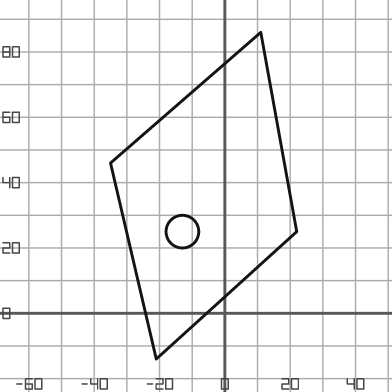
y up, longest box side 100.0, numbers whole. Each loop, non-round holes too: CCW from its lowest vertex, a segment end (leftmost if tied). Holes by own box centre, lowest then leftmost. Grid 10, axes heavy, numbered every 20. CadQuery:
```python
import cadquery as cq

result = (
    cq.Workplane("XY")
    .moveTo(-21.0, -14.0)
    .lineTo(22.0, 25.0)
    .lineTo(11.0, 86.0)
    .lineTo(-35.0, 46.0)
    .close()
    .moveTo(-13.0, 25.0)
    .circle(5.0)
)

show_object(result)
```